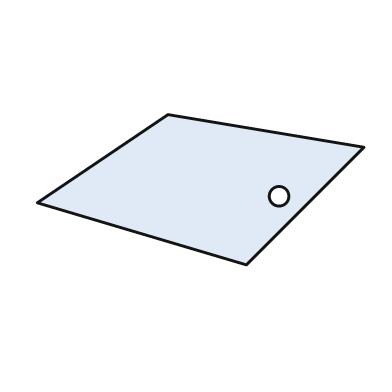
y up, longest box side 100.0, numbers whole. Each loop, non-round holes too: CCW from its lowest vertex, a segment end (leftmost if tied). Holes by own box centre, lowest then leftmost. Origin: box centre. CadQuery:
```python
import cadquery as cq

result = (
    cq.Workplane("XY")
    .moveTo(14.0, -23.0)
    .lineTo(50.0, 13.0)
    .lineTo(-10.0, 23.0)
    .lineTo(-50.0, -4.0)
    .close()
    .moveTo(24.0, -2.0)
    .circle(3.0)
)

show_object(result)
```